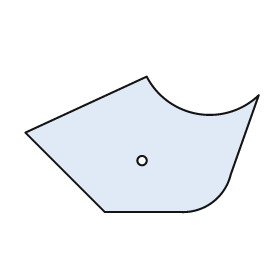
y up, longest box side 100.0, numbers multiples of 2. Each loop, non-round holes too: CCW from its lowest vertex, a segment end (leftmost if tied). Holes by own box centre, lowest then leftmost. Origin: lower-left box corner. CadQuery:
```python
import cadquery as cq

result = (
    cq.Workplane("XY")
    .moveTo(34.0, 0.0)
    .lineTo(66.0, 0.0)
    .threePointArc((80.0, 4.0), (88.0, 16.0))
    .lineTo(100.0, 50.0)
    .threePointArc((74.0, 42.0), (52.0, 58.0))
    .lineTo(0.0, 34.0)
    .close()
    .moveTo(50.0, 22.0)
    .circle(2.0)
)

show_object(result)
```